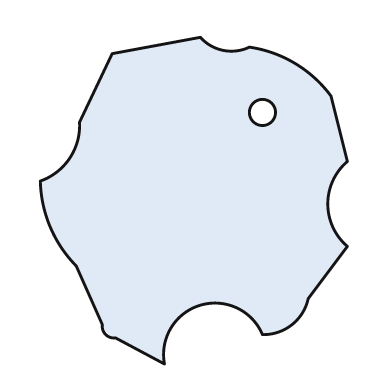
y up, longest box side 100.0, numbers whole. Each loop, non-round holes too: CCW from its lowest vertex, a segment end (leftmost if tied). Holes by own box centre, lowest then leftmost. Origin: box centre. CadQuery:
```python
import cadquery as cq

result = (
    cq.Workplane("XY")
    .moveTo(-9.0, -50.0)
    .threePointArc((2.0, -32.0), (21.0, -41.0))
    .threePointArc((30.0, -38.0), (35.0, -30.0))
    .lineTo(47.0, -14.0)
    .threePointArc((41.0, -1.0), (47.0, 12.0))
    .lineTo(42.0, 32.0)
    .threePointArc((31.0, 42.0), (17.0, 47.0))
    .threePointArc((9.0, 46.0), (2.0, 50.0))
    .lineTo(-25.0, 45.0)
    .lineTo(-35.0, 24.0)
    .threePointArc((-38.0, 13.0), (-47.0, 6.0))
    .threePointArc((-44.0, -8.0), (-36.0, -20.0))
    .lineTo(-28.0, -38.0)
    .threePointArc((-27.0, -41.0), (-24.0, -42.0))
    .close()
    .moveTo(21.0, 27.0)
    .circle(4.0)
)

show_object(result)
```